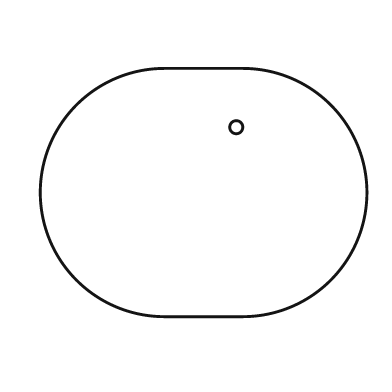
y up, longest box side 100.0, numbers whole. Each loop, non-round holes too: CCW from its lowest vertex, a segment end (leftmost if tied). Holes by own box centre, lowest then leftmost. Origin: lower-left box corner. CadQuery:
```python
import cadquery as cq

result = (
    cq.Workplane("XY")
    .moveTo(38.0, 0.0)
    .lineTo(62.0, 0.0)
    .threePointArc((100.0, 38.0), (62.0, 76.0))
    .lineTo(38.0, 76.0)
    .threePointArc((0.0, 38.0), (38.0, 0.0))
    .close()
    .moveTo(60.0, 58.0)
    .circle(2.0)
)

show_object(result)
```